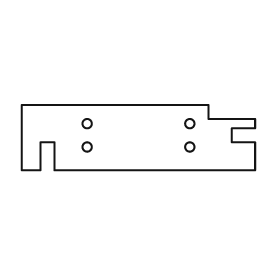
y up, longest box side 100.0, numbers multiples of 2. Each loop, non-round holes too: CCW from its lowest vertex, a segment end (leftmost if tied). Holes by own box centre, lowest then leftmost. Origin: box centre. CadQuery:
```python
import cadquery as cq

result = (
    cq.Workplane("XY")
    .moveTo(-50.0, -14.0)
    .lineTo(-42.0, -14.0)
    .lineTo(-42.0, -2.0)
    .lineTo(-36.0, -2.0)
    .lineTo(-36.0, -14.0)
    .lineTo(50.0, -14.0)
    .lineTo(50.0, -2.0)
    .lineTo(40.0, -2.0)
    .lineTo(40.0, 4.0)
    .lineTo(50.0, 4.0)
    .lineTo(50.0, 8.0)
    .lineTo(30.0, 8.0)
    .lineTo(30.0, 14.0)
    .lineTo(-50.0, 14.0)
    .close()
    .moveTo(-22.0, -4.0)
    .circle(2.0)
    .moveTo(22.0, -4.0)
    .circle(2.0)
    .moveTo(-22.0, 6.0)
    .circle(2.0)
    .moveTo(22.0, 6.0)
    .circle(2.0)
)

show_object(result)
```